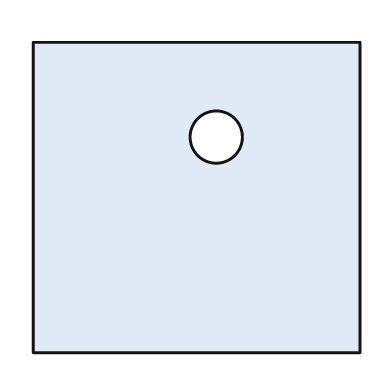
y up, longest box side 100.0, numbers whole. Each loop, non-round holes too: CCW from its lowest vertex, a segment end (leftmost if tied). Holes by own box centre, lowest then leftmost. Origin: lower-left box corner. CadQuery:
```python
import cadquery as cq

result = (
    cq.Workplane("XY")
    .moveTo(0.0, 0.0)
    .lineTo(100.0, 0.0)
    .lineTo(100.0, 95.0)
    .lineTo(0.0, 95.0)
    .close()
    .moveTo(56.0, 66.0)
    .circle(8.0)
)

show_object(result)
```